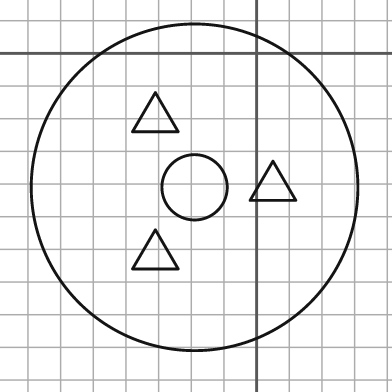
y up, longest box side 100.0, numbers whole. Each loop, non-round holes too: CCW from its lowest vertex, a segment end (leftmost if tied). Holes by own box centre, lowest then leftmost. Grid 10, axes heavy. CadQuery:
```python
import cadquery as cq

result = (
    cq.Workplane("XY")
    .moveTo(-19.0, -41.0)
    .circle(50.0)
    .moveTo(-38.0, -66.0)
    .lineTo(-24.0, -66.0)
    .lineTo(-31.0, -54.0)
    .close()
    .moveTo(-19.0, -41.0)
    .circle(10.0)
    .moveTo(-2.0, -45.0)
    .lineTo(12.0, -45.0)
    .lineTo(5.0, -33.0)
    .close()
    .moveTo(-38.0, -24.0)
    .lineTo(-24.0, -24.0)
    .lineTo(-31.0, -12.0)
    .close()
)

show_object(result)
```